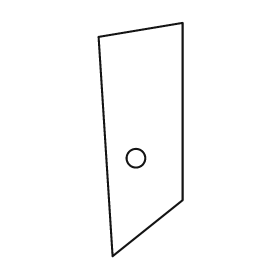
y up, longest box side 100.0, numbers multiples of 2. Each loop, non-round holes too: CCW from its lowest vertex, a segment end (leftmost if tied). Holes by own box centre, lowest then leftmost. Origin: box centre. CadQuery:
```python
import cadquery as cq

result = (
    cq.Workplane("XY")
    .moveTo(-12.0, -50.0)
    .lineTo(18.0, -26.0)
    .lineTo(18.0, 50.0)
    .lineTo(-18.0, 44.0)
    .close()
    .moveTo(-2.0, -8.0)
    .circle(4.0)
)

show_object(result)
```